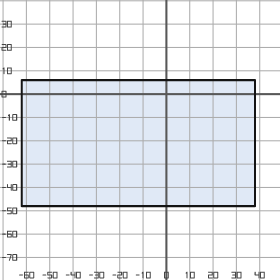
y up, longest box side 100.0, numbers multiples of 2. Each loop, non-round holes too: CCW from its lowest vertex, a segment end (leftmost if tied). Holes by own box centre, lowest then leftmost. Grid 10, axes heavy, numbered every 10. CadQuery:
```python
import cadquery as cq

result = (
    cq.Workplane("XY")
    .moveTo(-62.0, -48.0)
    .lineTo(38.0, -48.0)
    .lineTo(38.0, 6.0)
    .lineTo(-62.0, 6.0)
    .close()
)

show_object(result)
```